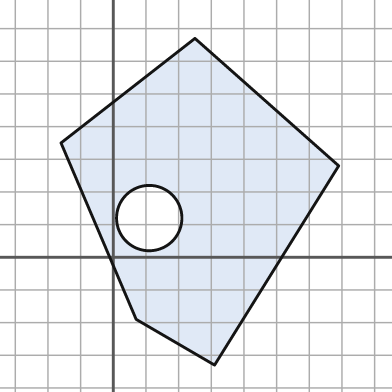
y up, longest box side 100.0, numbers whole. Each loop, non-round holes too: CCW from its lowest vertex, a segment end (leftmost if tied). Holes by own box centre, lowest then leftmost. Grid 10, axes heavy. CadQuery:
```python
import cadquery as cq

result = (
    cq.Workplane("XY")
    .moveTo(31.0, -33.0)
    .lineTo(69.0, 28.0)
    .lineTo(25.0, 67.0)
    .lineTo(-16.0, 35.0)
    .lineTo(7.0, -19.0)
    .close()
    .moveTo(11.0, 12.0)
    .circle(10.0)
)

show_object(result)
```